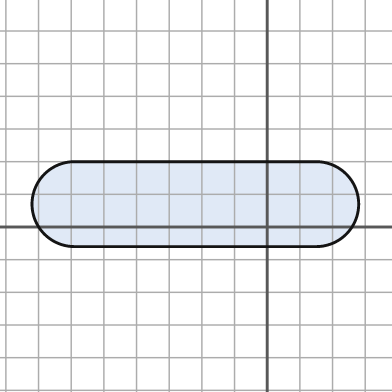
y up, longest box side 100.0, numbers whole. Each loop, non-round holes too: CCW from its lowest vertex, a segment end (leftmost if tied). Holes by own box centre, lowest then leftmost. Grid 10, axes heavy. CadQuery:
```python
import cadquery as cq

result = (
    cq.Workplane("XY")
    .moveTo(-59.0, -6.0)
    .lineTo(15.0, -6.0)
    .threePointArc((28.0, 7.0), (15.0, 20.0))
    .lineTo(-59.0, 20.0)
    .threePointArc((-72.0, 7.0), (-59.0, -6.0))
    .close()
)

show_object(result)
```